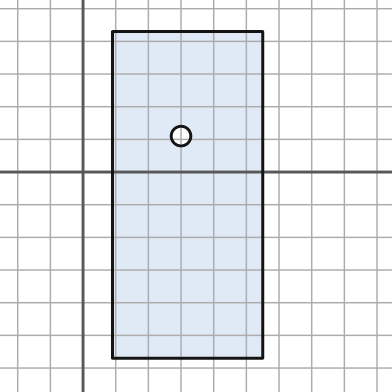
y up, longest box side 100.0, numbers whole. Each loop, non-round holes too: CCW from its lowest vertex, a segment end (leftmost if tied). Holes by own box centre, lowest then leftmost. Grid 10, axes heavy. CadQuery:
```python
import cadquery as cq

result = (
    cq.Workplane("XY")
    .moveTo(9.0, -57.0)
    .lineTo(55.0, -57.0)
    .lineTo(55.0, 43.0)
    .lineTo(9.0, 43.0)
    .close()
    .moveTo(30.0, 11.0)
    .circle(3.0)
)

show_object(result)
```